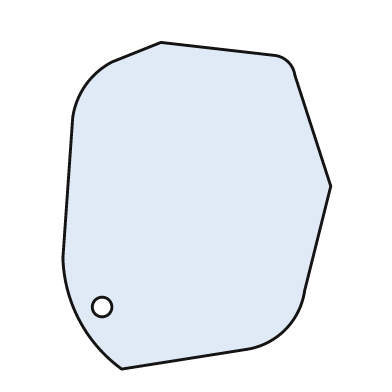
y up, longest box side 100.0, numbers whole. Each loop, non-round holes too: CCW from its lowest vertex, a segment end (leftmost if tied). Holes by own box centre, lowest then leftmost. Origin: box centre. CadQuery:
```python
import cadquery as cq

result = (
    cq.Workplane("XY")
    .moveTo(-23.0, -50.0)
    .lineTo(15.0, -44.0)
    .threePointArc((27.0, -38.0), (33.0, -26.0))
    .lineTo(41.0, 6.0)
    .lineTo(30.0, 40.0)
    .threePointArc((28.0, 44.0), (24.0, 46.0))
    .lineTo(-11.0, 50.0)
    .lineTo(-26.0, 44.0)
    .threePointArc((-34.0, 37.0), (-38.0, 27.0))
    .lineTo(-41.0, -16.0)
    .threePointArc((-36.0, -35.0), (-23.0, -50.0))
    .close()
    .moveTo(-29.0, -31.0)
    .circle(3.0)
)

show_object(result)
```